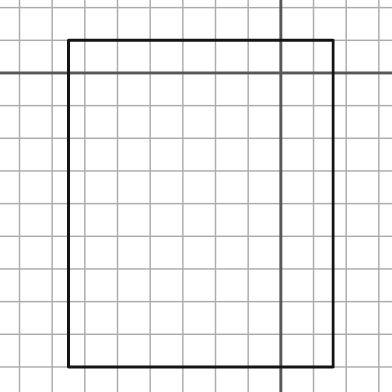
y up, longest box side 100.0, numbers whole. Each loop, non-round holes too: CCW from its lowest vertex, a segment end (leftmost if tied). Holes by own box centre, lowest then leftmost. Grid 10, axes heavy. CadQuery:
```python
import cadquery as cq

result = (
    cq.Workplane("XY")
    .moveTo(-65.0, -90.0)
    .lineTo(16.0, -90.0)
    .lineTo(16.0, 10.0)
    .lineTo(-65.0, 10.0)
    .close()
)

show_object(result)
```